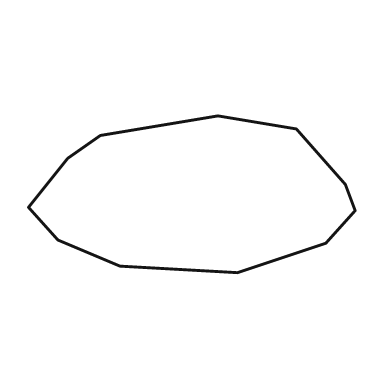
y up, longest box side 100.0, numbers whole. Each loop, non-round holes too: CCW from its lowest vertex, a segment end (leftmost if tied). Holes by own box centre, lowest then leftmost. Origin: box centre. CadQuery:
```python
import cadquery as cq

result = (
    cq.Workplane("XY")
    .moveTo(14.0, -24.0)
    .lineTo(41.0, -15.0)
    .lineTo(50.0, -5.0)
    .lineTo(47.0, 3.0)
    .lineTo(32.0, 20.0)
    .lineTo(8.0, 24.0)
    .lineTo(-28.0, 18.0)
    .lineTo(-38.0, 11.0)
    .lineTo(-50.0, -4.0)
    .lineTo(-41.0, -14.0)
    .lineTo(-22.0, -22.0)
    .close()
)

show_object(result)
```